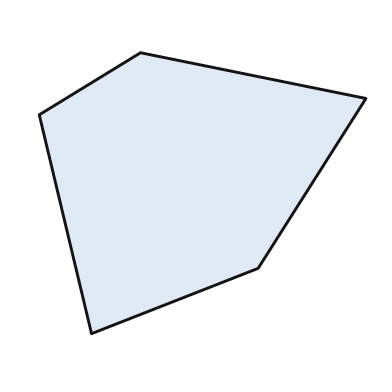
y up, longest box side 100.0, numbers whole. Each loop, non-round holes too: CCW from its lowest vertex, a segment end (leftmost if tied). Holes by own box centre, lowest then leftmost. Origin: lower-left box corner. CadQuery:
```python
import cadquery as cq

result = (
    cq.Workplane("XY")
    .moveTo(16.0, 0.0)
    .lineTo(67.0, 20.0)
    .lineTo(100.0, 72.0)
    .lineTo(31.0, 86.0)
    .lineTo(0.0, 67.0)
    .close()
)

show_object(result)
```